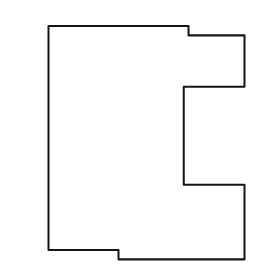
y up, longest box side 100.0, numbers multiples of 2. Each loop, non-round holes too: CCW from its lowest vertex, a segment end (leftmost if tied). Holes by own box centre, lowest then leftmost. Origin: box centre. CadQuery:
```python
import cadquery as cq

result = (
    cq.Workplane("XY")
    .moveTo(-12.0, -50.0)
    .lineTo(42.0, -50.0)
    .lineTo(42.0, -18.0)
    .lineTo(16.0, -18.0)
    .lineTo(16.0, 24.0)
    .lineTo(42.0, 24.0)
    .lineTo(42.0, 46.0)
    .lineTo(18.0, 46.0)
    .lineTo(18.0, 50.0)
    .lineTo(-42.0, 50.0)
    .lineTo(-42.0, -46.0)
    .lineTo(-12.0, -46.0)
    .close()
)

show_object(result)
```